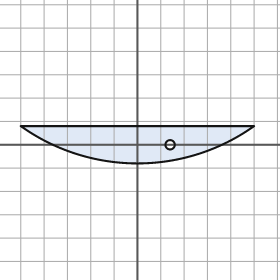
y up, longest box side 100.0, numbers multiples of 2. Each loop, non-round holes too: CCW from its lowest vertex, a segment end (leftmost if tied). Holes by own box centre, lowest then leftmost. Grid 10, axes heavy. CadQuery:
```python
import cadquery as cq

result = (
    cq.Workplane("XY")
    .moveTo(-50.0, 8.0)
    .threePointArc((0.0, -8.0), (50.0, 8.0))
    .close()
    .moveTo(14.0, 0.0)
    .circle(2.0)
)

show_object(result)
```